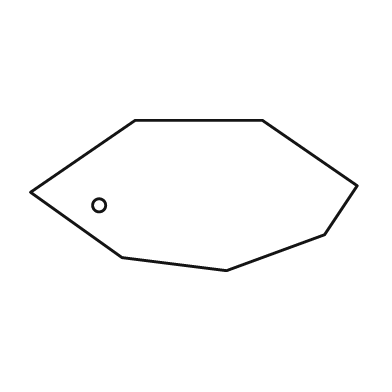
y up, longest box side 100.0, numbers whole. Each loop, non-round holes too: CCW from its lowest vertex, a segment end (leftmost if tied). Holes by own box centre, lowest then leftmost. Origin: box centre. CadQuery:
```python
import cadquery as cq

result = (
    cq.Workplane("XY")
    .moveTo(10.0, -23.0)
    .lineTo(40.0, -12.0)
    .lineTo(50.0, 3.0)
    .lineTo(21.0, 23.0)
    .lineTo(-18.0, 23.0)
    .lineTo(-50.0, 1.0)
    .lineTo(-22.0, -19.0)
    .close()
    .moveTo(-29.0, -3.0)
    .circle(2.0)
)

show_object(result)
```